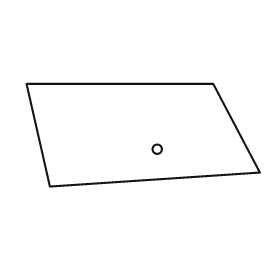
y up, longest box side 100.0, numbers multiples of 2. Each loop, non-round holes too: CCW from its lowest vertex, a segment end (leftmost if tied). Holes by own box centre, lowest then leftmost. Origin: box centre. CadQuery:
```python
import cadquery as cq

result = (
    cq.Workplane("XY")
    .moveTo(-40.0, -22.0)
    .lineTo(50.0, -16.0)
    .lineTo(30.0, 22.0)
    .lineTo(-50.0, 22.0)
    .close()
    .moveTo(6.0, -6.0)
    .circle(2.0)
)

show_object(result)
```